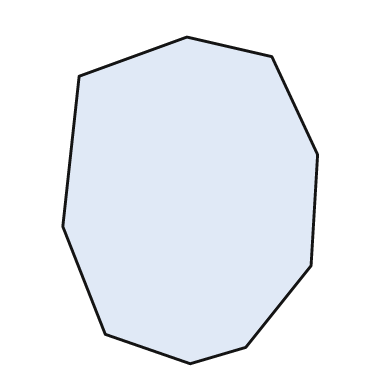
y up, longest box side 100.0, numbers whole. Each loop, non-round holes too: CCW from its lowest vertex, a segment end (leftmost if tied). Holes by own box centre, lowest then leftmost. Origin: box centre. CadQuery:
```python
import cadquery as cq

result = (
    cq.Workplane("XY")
    .moveTo(0.0, -50.0)
    .lineTo(17.0, -45.0)
    .lineTo(37.0, -20.0)
    .lineTo(39.0, 14.0)
    .lineTo(25.0, 44.0)
    .lineTo(-1.0, 50.0)
    .lineTo(-34.0, 38.0)
    .lineTo(-39.0, -8.0)
    .lineTo(-26.0, -41.0)
    .close()
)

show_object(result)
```